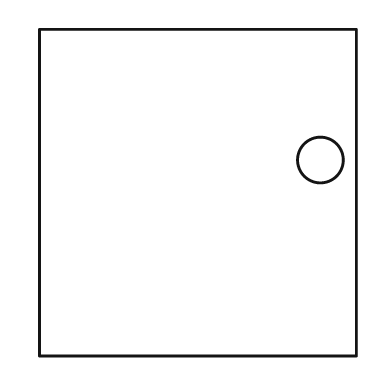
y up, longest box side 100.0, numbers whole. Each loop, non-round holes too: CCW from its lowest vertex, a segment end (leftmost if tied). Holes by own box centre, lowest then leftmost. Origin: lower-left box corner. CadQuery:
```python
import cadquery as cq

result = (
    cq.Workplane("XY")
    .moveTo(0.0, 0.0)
    .lineTo(97.0, 0.0)
    .lineTo(97.0, 100.0)
    .lineTo(0.0, 100.0)
    .close()
    .moveTo(86.0, 60.0)
    .circle(7.0)
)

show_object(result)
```